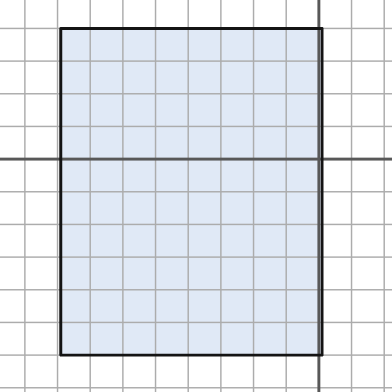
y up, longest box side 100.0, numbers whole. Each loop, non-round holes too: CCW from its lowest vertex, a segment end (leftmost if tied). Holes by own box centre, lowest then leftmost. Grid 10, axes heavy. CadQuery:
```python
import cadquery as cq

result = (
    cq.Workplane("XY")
    .moveTo(-79.0, -60.0)
    .lineTo(1.0, -60.0)
    .lineTo(1.0, 40.0)
    .lineTo(-79.0, 40.0)
    .close()
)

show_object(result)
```